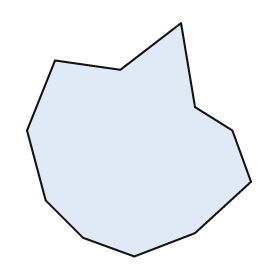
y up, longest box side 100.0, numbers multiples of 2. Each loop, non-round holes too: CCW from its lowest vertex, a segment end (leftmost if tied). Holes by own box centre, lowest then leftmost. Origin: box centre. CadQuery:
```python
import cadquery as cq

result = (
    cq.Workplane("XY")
    .moveTo(-2.0, -50.0)
    .lineTo(24.0, -40.0)
    .lineTo(48.0, -18.0)
    .lineTo(40.0, 4.0)
    .lineTo(24.0, 14.0)
    .lineTo(18.0, 50.0)
    .lineTo(-8.0, 30.0)
    .lineTo(-36.0, 34.0)
    .lineTo(-48.0, 4.0)
    .lineTo(-40.0, -26.0)
    .lineTo(-24.0, -42.0)
    .close()
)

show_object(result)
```